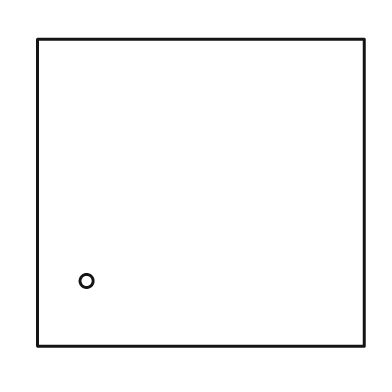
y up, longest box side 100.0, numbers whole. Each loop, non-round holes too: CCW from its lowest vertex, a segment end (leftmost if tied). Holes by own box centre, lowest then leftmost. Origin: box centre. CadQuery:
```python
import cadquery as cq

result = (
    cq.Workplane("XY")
    .moveTo(-50.0, -47.0)
    .lineTo(50.0, -47.0)
    .lineTo(50.0, 47.0)
    .lineTo(-50.0, 47.0)
    .close()
    .moveTo(-35.0, -27.0)
    .circle(2.0)
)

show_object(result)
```